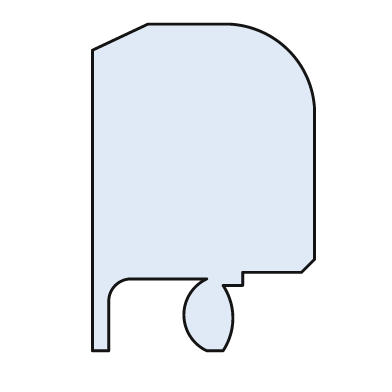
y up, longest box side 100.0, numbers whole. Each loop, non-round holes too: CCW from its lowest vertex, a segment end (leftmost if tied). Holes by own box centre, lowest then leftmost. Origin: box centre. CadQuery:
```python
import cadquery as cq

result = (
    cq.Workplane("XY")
    .moveTo(-34.0, -50.0)
    .lineTo(-29.0, -50.0)
    .lineTo(-29.0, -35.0)
    .threePointArc((-27.0, -30.0), (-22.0, -28.0))
    .lineTo(1.0, -28.0)
    .threePointArc((-6.0, -39.0), (1.0, -50.0))
    .lineTo(6.0, -50.0)
    .threePointArc((9.0, -40.0), (6.0, -30.0))
    .lineTo(12.0, -30.0)
    .lineTo(12.0, -26.0)
    .lineTo(30.0, -26.0)
    .lineTo(34.0, -22.0)
    .lineTo(34.0, 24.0)
    .threePointArc((26.0, 42.0), (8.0, 50.0))
    .lineTo(-17.0, 50.0)
    .lineTo(-34.0, 42.0)
    .close()
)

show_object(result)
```